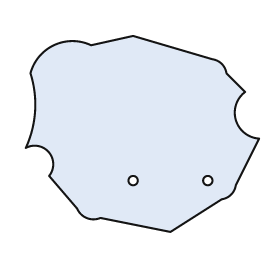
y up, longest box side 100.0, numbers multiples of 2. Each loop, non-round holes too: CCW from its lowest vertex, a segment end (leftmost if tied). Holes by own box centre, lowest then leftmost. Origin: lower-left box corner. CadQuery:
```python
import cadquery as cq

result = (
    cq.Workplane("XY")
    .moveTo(62.0, 0.0)
    .lineTo(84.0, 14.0)
    .threePointArc((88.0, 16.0), (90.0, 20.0))
    .lineTo(100.0, 40.0)
    .threePointArc((90.0, 48.0), (94.0, 60.0))
    .lineTo(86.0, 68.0)
    .threePointArc((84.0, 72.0), (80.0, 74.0))
    .lineTo(46.0, 84.0)
    .lineTo(28.0, 80.0)
    .threePointArc((12.0, 80.0), (2.0, 68.0))
    .threePointArc((4.0, 52.0), (0.0, 36.0))
    .threePointArc((10.0, 34.0), (10.0, 24.0))
    .lineTo(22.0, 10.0)
    .threePointArc((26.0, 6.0), (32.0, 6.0))
    .close()
    .moveTo(46.0, 22.0)
    .circle(2.0)
    .moveTo(78.0, 22.0)
    .circle(2.0)
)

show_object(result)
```